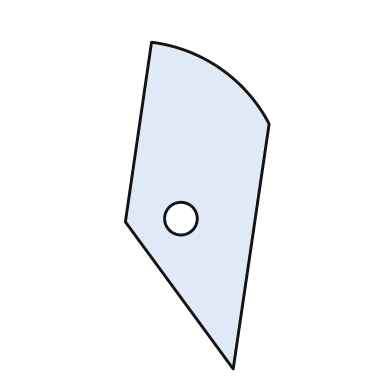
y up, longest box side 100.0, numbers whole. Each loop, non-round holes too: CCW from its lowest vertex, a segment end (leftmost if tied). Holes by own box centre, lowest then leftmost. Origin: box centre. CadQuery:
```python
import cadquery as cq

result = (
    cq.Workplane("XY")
    .moveTo(11.0, -50.0)
    .lineTo(22.0, 25.0)
    .threePointArc((7.0, 42.0), (-14.0, 50.0))
    .lineTo(-22.0, -5.0)
    .close()
    .moveTo(-5.0, -4.0)
    .circle(5.0)
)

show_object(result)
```